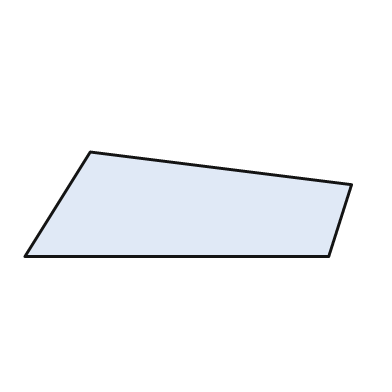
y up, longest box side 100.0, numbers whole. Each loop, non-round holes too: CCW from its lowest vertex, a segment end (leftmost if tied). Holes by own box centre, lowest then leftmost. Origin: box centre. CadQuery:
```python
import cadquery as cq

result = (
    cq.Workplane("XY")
    .moveTo(-50.0, -16.0)
    .lineTo(43.0, -16.0)
    .lineTo(50.0, 6.0)
    .lineTo(-30.0, 16.0)
    .close()
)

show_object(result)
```